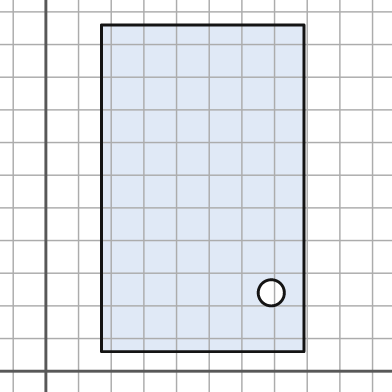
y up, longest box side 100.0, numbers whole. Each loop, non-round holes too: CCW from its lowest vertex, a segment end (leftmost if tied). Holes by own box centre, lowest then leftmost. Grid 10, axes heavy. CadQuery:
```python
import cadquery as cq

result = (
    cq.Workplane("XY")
    .moveTo(17.0, 6.0)
    .lineTo(79.0, 6.0)
    .lineTo(79.0, 106.0)
    .lineTo(17.0, 106.0)
    .close()
    .moveTo(69.0, 24.0)
    .circle(4.0)
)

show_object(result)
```